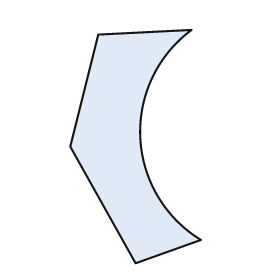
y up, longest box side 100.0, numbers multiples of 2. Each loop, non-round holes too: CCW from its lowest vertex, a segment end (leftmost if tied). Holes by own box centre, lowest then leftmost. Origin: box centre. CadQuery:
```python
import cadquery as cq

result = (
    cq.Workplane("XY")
    .moveTo(0.0, -50.0)
    .lineTo(28.0, -40.0)
    .threePointArc((2.0, 4.0), (24.0, 50.0))
    .lineTo(-16.0, 48.0)
    .lineTo(-28.0, 0.0)
    .close()
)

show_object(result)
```